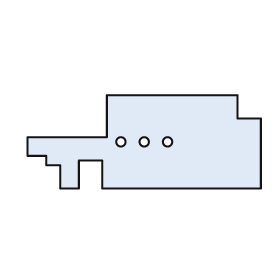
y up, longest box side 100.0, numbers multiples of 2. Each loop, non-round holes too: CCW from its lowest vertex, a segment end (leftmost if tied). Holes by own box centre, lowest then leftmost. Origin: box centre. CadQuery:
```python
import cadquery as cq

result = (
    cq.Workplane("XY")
    .moveTo(-36.0, -20.0)
    .lineTo(-28.0, -20.0)
    .lineTo(-28.0, -8.0)
    .lineTo(-18.0, -8.0)
    .lineTo(-18.0, -20.0)
    .lineTo(50.0, -20.0)
    .lineTo(50.0, 10.0)
    .lineTo(40.0, 10.0)
    .lineTo(40.0, 20.0)
    .lineTo(-16.0, 20.0)
    .lineTo(-16.0, 2.0)
    .lineTo(-50.0, 2.0)
    .lineTo(-50.0, -6.0)
    .lineTo(-42.0, -6.0)
    .lineTo(-42.0, -10.0)
    .lineTo(-36.0, -10.0)
    .close()
    .moveTo(-10.0, 0.0)
    .circle(2.0)
    .moveTo(0.0, 0.0)
    .circle(2.0)
    .moveTo(10.0, 0.0)
    .circle(2.0)
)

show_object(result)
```